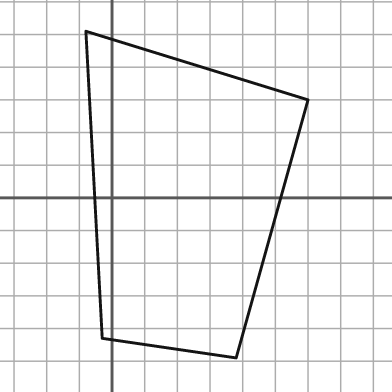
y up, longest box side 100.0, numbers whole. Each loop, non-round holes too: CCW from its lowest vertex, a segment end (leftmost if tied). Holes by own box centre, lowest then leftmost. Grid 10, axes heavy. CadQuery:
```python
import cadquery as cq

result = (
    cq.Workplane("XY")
    .moveTo(38.0, -49.0)
    .lineTo(60.0, 30.0)
    .lineTo(-8.0, 51.0)
    .lineTo(-3.0, -43.0)
    .close()
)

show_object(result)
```